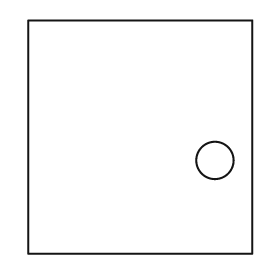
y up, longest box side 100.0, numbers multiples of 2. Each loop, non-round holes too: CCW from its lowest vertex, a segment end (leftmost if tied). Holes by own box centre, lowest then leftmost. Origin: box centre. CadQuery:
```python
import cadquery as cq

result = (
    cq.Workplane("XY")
    .moveTo(-48.0, -50.0)
    .lineTo(48.0, -50.0)
    .lineTo(48.0, 50.0)
    .lineTo(-48.0, 50.0)
    .close()
    .moveTo(32.0, -10.0)
    .circle(8.0)
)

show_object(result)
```